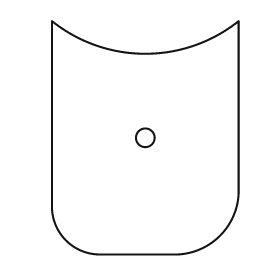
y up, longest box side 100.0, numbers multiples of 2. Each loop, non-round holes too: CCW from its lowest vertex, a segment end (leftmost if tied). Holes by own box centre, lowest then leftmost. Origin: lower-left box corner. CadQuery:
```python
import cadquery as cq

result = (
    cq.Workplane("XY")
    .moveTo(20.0, 0.0)
    .lineTo(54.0, 0.0)
    .threePointArc((72.0, 8.0), (80.0, 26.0))
    .lineTo(80.0, 100.0)
    .threePointArc((40.0, 86.0), (0.0, 100.0))
    .lineTo(0.0, 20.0)
    .threePointArc((6.0, 6.0), (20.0, 0.0))
    .close()
    .moveTo(40.0, 50.0)
    .circle(4.0)
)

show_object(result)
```